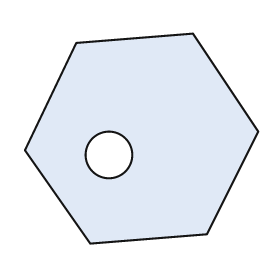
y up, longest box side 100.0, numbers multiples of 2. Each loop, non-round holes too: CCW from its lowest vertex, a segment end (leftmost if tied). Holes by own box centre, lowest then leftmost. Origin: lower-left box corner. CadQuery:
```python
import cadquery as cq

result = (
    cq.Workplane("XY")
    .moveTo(28.0, 0.0)
    .lineTo(78.0, 4.0)
    .lineTo(100.0, 48.0)
    .lineTo(72.0, 90.0)
    .lineTo(22.0, 86.0)
    .lineTo(0.0, 40.0)
    .close()
    .moveTo(36.0, 38.0)
    .circle(10.0)
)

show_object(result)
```